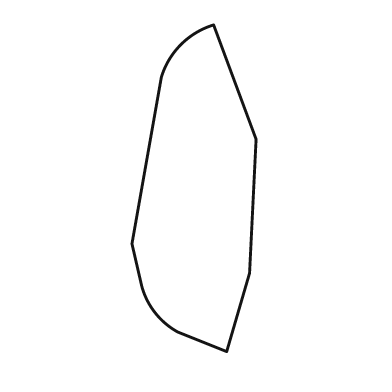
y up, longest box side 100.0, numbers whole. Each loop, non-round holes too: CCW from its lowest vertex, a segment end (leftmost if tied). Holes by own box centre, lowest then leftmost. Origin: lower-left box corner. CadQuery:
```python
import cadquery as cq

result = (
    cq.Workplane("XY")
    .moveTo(29.0, 0.0)
    .lineTo(36.0, 24.0)
    .lineTo(38.0, 65.0)
    .lineTo(25.0, 100.0)
    .threePointArc((15.0, 94.0), (9.0, 84.0))
    .lineTo(0.0, 33.0)
    .lineTo(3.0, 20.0)
    .threePointArc((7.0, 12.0), (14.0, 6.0))
    .close()
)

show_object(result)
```